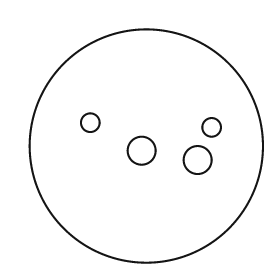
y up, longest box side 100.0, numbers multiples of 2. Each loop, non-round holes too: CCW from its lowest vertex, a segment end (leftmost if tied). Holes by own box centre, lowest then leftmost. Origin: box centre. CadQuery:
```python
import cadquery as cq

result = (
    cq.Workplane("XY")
    .moveTo(0.0, 0.0)
    .circle(50.0)
    .moveTo(22.0, -6.0)
    .circle(6.0)
    .moveTo(-2.0, -2.0)
    .circle(6.0)
    .moveTo(28.0, 8.0)
    .circle(4.0)
    .moveTo(-24.0, 10.0)
    .circle(4.0)
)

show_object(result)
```